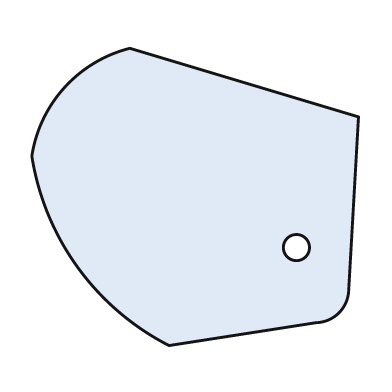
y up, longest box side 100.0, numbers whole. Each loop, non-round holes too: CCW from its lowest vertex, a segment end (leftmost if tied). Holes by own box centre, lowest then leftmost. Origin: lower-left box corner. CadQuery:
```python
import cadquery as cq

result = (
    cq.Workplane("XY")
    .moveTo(42.0, 0.0)
    .lineTo(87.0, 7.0)
    .threePointArc((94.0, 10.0), (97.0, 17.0))
    .lineTo(100.0, 70.0)
    .lineTo(30.0, 91.0)
    .threePointArc((10.0, 79.0), (0.0, 58.0))
    .threePointArc((14.0, 24.0), (42.0, 0.0))
    .close()
    .moveTo(81.0, 30.0)
    .circle(4.0)
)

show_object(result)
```